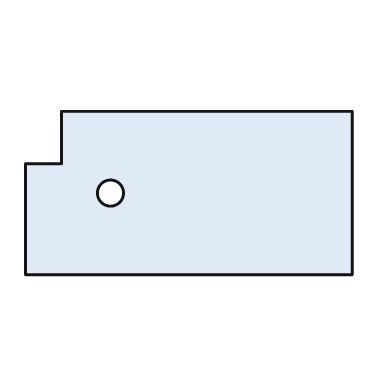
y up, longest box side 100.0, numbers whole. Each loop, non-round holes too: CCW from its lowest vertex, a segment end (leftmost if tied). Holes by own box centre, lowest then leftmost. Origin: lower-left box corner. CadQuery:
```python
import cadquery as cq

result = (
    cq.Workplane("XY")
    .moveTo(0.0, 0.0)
    .lineTo(100.0, 0.0)
    .lineTo(100.0, 50.0)
    .lineTo(11.0, 50.0)
    .lineTo(11.0, 34.0)
    .lineTo(0.0, 34.0)
    .close()
    .moveTo(26.0, 25.0)
    .circle(4.0)
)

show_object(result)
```